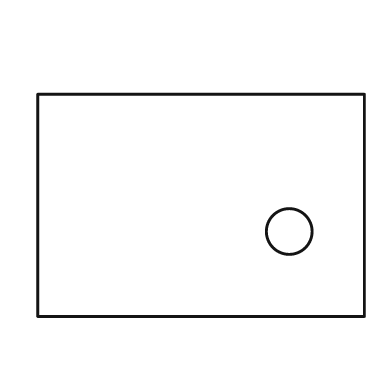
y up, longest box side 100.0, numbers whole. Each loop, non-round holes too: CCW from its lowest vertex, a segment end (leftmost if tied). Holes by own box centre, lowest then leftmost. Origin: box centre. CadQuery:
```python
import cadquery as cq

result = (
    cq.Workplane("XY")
    .moveTo(-50.0, -34.0)
    .lineTo(50.0, -34.0)
    .lineTo(50.0, 34.0)
    .lineTo(-50.0, 34.0)
    .close()
    .moveTo(27.0, -8.0)
    .circle(7.0)
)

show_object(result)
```